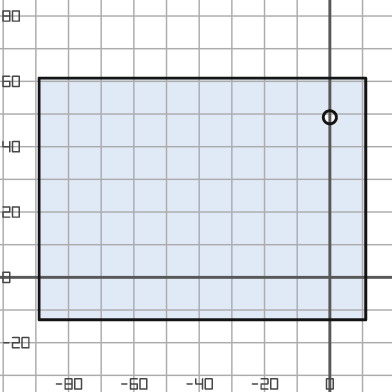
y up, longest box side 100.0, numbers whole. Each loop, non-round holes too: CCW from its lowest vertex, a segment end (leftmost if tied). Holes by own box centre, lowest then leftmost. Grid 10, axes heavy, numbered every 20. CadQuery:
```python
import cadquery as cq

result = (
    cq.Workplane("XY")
    .moveTo(-89.0, -13.0)
    .lineTo(11.0, -13.0)
    .lineTo(11.0, 61.0)
    .lineTo(-89.0, 61.0)
    .close()
    .moveTo(0.0, 49.0)
    .circle(2.0)
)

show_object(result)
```